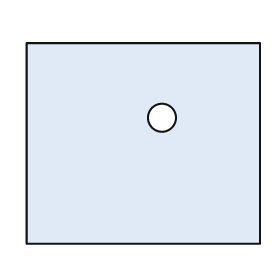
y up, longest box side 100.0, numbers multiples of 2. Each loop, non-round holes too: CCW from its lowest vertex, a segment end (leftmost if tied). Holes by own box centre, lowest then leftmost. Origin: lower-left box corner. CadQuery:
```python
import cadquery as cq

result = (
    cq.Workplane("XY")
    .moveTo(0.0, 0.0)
    .lineTo(100.0, 0.0)
    .lineTo(100.0, 86.0)
    .lineTo(0.0, 86.0)
    .close()
    .moveTo(58.0, 54.0)
    .circle(6.0)
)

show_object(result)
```